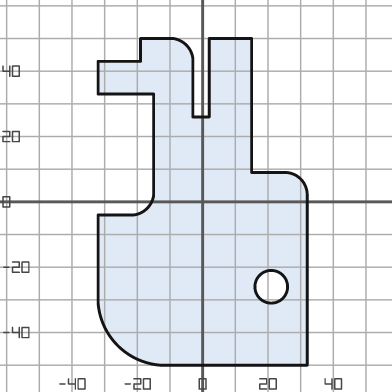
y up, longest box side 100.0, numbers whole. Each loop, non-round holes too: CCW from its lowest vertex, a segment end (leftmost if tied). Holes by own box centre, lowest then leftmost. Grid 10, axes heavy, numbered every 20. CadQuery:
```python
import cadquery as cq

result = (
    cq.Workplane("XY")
    .moveTo(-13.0, -50.0)
    .lineTo(32.0, -50.0)
    .lineTo(32.0, 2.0)
    .threePointArc((30.0, 7.0), (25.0, 9.0))
    .lineTo(15.0, 9.0)
    .lineTo(15.0, 50.0)
    .lineTo(2.0, 50.0)
    .lineTo(2.0, 26.0)
    .lineTo(-3.0, 26.0)
    .lineTo(-3.0, 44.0)
    .threePointArc((-5.0, 48.0), (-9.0, 50.0))
    .lineTo(-19.0, 50.0)
    .lineTo(-19.0, 43.0)
    .lineTo(-32.0, 43.0)
    .lineTo(-32.0, 33.0)
    .lineTo(-15.0, 33.0)
    .lineTo(-15.0, 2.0)
    .threePointArc((-17.0, -2.0), (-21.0, -4.0))
    .lineTo(-32.0, -4.0)
    .lineTo(-32.0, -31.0)
    .threePointArc((-26.0, -44.0), (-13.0, -50.0))
    .close()
    .moveTo(21.0, -26.0)
    .circle(5.0)
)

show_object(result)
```